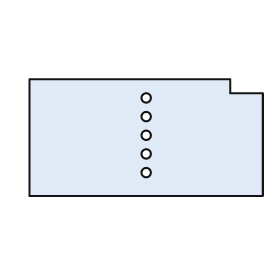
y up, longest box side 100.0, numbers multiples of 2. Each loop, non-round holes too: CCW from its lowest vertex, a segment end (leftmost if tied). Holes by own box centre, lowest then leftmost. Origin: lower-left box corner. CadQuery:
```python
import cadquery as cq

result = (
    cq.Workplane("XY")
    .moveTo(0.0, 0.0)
    .lineTo(100.0, 0.0)
    .lineTo(100.0, 44.0)
    .lineTo(86.0, 44.0)
    .lineTo(86.0, 50.0)
    .lineTo(0.0, 50.0)
    .close()
    .moveTo(50.0, 10.0)
    .circle(2.0)
    .moveTo(50.0, 18.0)
    .circle(2.0)
    .moveTo(50.0, 26.0)
    .circle(2.0)
    .moveTo(50.0, 34.0)
    .circle(2.0)
    .moveTo(50.0, 42.0)
    .circle(2.0)
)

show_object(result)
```